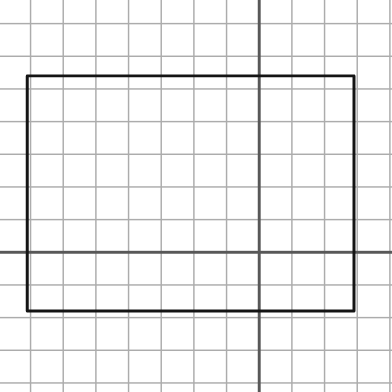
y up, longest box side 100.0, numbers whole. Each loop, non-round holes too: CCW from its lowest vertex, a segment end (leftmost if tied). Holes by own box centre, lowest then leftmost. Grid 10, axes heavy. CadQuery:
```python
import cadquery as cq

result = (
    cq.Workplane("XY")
    .moveTo(-71.0, -18.0)
    .lineTo(29.0, -18.0)
    .lineTo(29.0, 54.0)
    .lineTo(-71.0, 54.0)
    .close()
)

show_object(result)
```